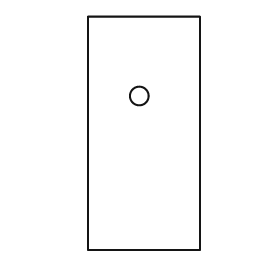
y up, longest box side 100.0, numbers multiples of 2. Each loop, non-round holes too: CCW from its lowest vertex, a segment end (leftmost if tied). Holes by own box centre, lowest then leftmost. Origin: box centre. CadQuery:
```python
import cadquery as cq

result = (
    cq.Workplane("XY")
    .moveTo(-24.0, -50.0)
    .lineTo(24.0, -50.0)
    .lineTo(24.0, 50.0)
    .lineTo(-24.0, 50.0)
    .close()
    .moveTo(-2.0, 16.0)
    .circle(4.0)
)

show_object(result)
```